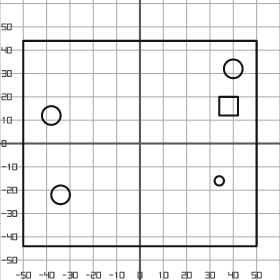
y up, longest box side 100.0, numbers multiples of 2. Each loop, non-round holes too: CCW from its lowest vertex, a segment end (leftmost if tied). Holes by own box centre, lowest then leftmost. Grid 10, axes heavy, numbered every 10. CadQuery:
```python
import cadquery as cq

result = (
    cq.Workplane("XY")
    .moveTo(-50.0, -44.0)
    .lineTo(50.0, -44.0)
    .lineTo(50.0, 44.0)
    .lineTo(-50.0, 44.0)
    .close()
    .moveTo(-34.0, -22.0)
    .circle(4.0)
    .moveTo(34.0, -16.0)
    .circle(2.0)
    .moveTo(-38.0, 12.0)
    .circle(4.0)
    .moveTo(34.0, 12.0)
    .lineTo(42.0, 12.0)
    .lineTo(42.0, 20.0)
    .lineTo(34.0, 20.0)
    .close()
    .moveTo(40.0, 32.0)
    .circle(4.0)
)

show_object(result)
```